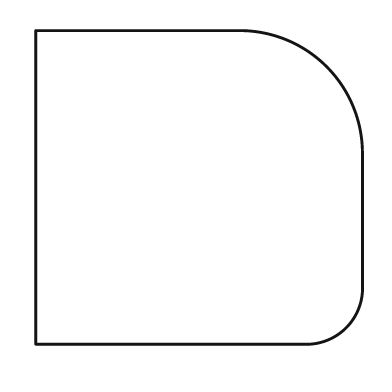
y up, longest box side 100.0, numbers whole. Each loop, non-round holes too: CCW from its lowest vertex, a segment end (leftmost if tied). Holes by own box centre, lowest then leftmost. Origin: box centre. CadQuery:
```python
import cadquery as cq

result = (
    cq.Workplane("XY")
    .moveTo(-50.0, -48.0)
    .lineTo(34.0, -48.0)
    .threePointArc((45.0, -43.0), (50.0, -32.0))
    .lineTo(50.0, 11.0)
    .threePointArc((39.0, 37.0), (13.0, 48.0))
    .lineTo(-50.0, 48.0)
    .close()
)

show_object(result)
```